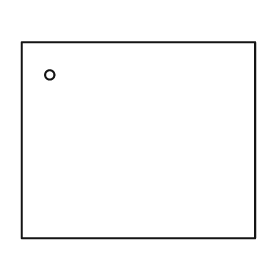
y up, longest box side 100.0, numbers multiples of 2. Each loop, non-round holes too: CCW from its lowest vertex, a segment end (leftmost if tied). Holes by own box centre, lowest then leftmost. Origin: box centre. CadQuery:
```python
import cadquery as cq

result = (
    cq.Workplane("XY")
    .moveTo(-50.0, -42.0)
    .lineTo(50.0, -42.0)
    .lineTo(50.0, 42.0)
    .lineTo(-50.0, 42.0)
    .close()
    .moveTo(-38.0, 28.0)
    .circle(2.0)
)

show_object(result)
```